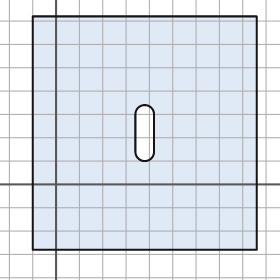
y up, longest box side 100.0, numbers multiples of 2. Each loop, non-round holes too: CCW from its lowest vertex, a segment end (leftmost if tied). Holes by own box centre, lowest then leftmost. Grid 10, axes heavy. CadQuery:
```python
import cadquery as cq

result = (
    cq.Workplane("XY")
    .moveTo(-10.0, -28.0)
    .lineTo(86.0, -28.0)
    .lineTo(86.0, 72.0)
    .lineTo(-10.0, 72.0)
    .close()
    .moveTo(34.0, 14.0)
    .threePointArc((38.0, 10.0), (42.0, 14.0))
    .lineTo(42.0, 30.0)
    .threePointArc((38.0, 34.0), (34.0, 30.0))
    .close()
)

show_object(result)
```